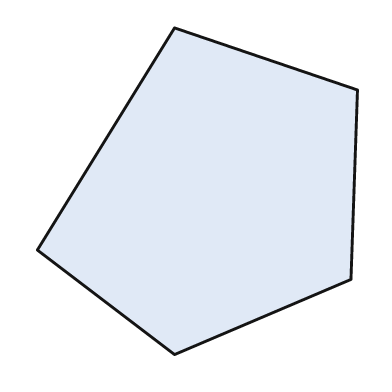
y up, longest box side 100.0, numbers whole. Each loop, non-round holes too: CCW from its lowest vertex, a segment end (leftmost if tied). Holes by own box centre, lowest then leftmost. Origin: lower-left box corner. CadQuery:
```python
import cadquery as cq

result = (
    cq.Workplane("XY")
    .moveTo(42.0, 0.0)
    .lineTo(96.0, 23.0)
    .lineTo(98.0, 81.0)
    .lineTo(42.0, 100.0)
    .lineTo(0.0, 32.0)
    .close()
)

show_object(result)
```